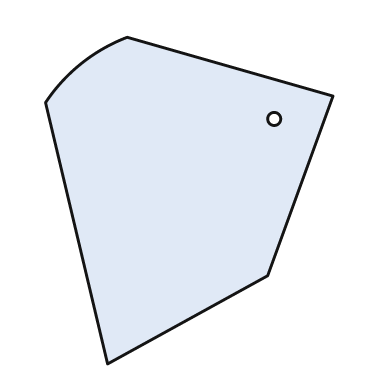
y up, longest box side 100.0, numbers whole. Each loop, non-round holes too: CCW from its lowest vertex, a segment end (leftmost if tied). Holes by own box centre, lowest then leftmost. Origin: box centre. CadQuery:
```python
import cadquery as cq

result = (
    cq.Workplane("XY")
    .moveTo(-25.0, -50.0)
    .lineTo(24.0, -23.0)
    .lineTo(44.0, 32.0)
    .lineTo(-19.0, 50.0)
    .threePointArc((-33.0, 42.0), (-44.0, 30.0))
    .close()
    .moveTo(26.0, 25.0)
    .circle(2.0)
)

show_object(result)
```